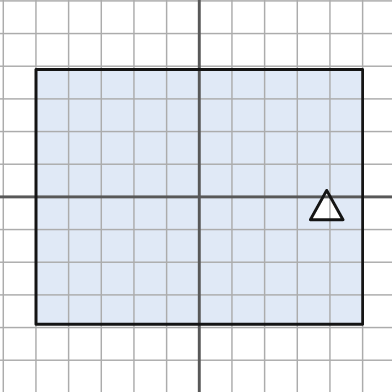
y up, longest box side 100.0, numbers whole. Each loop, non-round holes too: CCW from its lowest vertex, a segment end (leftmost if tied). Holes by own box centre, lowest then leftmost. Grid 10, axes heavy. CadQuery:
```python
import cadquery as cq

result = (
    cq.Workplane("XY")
    .moveTo(-50.0, -39.0)
    .lineTo(50.0, -39.0)
    .lineTo(50.0, 39.0)
    .lineTo(-50.0, 39.0)
    .close()
    .moveTo(34.0, -7.0)
    .lineTo(44.0, -7.0)
    .lineTo(39.0, 2.0)
    .close()
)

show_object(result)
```